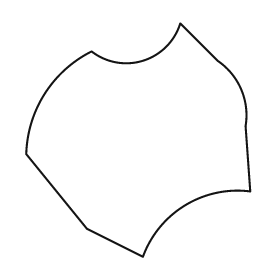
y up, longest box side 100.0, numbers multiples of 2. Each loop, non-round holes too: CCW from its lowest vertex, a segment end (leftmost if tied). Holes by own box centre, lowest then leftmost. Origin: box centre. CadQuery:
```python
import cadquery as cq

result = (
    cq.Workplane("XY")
    .moveTo(2.0, -50.0)
    .threePointArc((20.0, -28.0), (48.0, -22.0))
    .lineTo(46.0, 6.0)
    .threePointArc((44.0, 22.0), (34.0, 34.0))
    .lineTo(18.0, 50.0)
    .threePointArc((2.0, 34.0), (-20.0, 38.0))
    .threePointArc((-40.0, 20.0), (-48.0, -6.0))
    .lineTo(-22.0, -38.0)
    .close()
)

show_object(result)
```